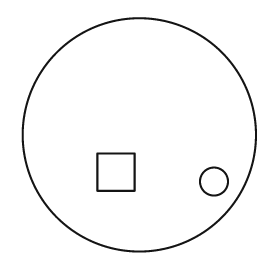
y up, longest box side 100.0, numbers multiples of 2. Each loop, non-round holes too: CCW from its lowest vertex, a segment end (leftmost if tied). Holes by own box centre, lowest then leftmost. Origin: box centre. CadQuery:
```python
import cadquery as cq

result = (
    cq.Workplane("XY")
    .moveTo(0.0, 0.0)
    .circle(50.0)
    .moveTo(32.0, -20.0)
    .circle(6.0)
    .moveTo(-18.0, -24.0)
    .lineTo(-2.0, -24.0)
    .lineTo(-2.0, -8.0)
    .lineTo(-18.0, -8.0)
    .close()
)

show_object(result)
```